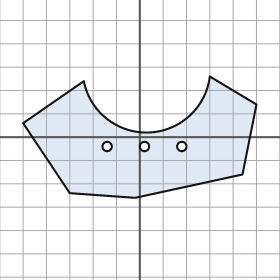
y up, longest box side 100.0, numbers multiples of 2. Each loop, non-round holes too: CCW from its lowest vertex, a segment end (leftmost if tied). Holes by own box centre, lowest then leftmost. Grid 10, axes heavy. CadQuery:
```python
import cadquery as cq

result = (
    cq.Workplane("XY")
    .moveTo(-2.0, -26.0)
    .lineTo(44.0, -16.0)
    .lineTo(50.0, 14.0)
    .lineTo(30.0, 26.0)
    .threePointArc((4.0, 2.0), (-24.0, 24.0))
    .lineTo(-50.0, 6.0)
    .lineTo(-30.0, -24.0)
    .close()
    .moveTo(-14.0, -4.0)
    .circle(2.0)
    .moveTo(2.0, -4.0)
    .circle(2.0)
    .moveTo(18.0, -4.0)
    .circle(2.0)
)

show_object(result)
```